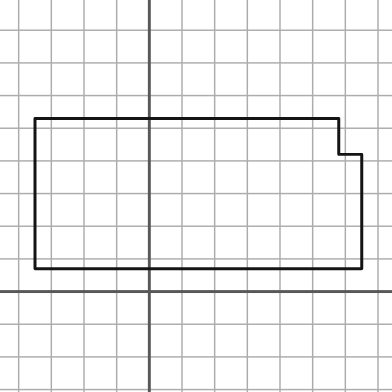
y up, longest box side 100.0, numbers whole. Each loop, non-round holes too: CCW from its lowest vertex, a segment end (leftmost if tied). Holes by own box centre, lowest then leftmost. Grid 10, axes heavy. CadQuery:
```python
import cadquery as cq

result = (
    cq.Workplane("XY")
    .moveTo(-35.0, 7.0)
    .lineTo(65.0, 7.0)
    .lineTo(65.0, 42.0)
    .lineTo(58.0, 42.0)
    .lineTo(58.0, 53.0)
    .lineTo(-35.0, 53.0)
    .close()
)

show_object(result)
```